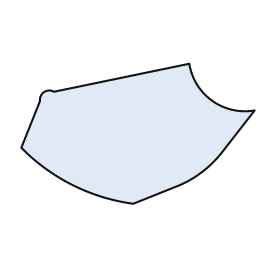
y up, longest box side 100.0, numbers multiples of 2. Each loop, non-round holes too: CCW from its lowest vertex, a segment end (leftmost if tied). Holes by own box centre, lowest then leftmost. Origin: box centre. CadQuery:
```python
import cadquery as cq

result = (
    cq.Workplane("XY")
    .moveTo(-2.0, -30.0)
    .lineTo(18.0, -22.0)
    .threePointArc((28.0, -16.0), (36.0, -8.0))
    .lineTo(50.0, 10.0)
    .threePointArc((32.0, 14.0), (22.0, 30.0))
    .lineTo(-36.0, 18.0)
    .threePointArc((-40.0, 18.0), (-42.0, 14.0))
    .lineTo(-50.0, -6.0)
    .threePointArc((-28.0, -22.0), (-2.0, -30.0))
    .close()
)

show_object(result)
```